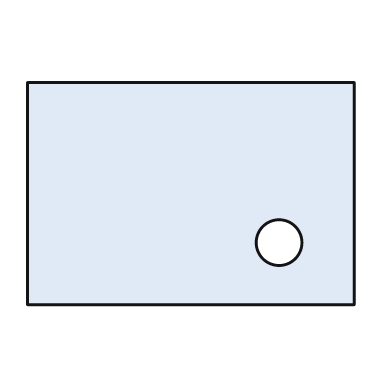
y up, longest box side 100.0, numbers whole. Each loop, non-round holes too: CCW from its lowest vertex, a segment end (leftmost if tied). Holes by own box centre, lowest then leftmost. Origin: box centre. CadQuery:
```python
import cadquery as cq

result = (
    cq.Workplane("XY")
    .moveTo(-50.0, -34.0)
    .lineTo(50.0, -34.0)
    .lineTo(50.0, 34.0)
    .lineTo(-50.0, 34.0)
    .close()
    .moveTo(27.0, -15.0)
    .circle(7.0)
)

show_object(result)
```